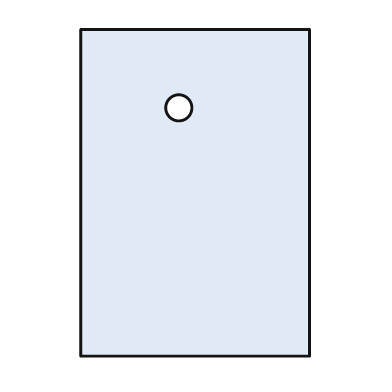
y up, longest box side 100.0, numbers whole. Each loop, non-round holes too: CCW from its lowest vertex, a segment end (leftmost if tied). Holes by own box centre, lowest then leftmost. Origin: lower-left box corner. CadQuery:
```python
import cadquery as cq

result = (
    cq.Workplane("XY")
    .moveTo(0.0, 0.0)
    .lineTo(70.0, 0.0)
    .lineTo(70.0, 100.0)
    .lineTo(0.0, 100.0)
    .close()
    .moveTo(30.0, 76.0)
    .circle(4.0)
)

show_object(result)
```